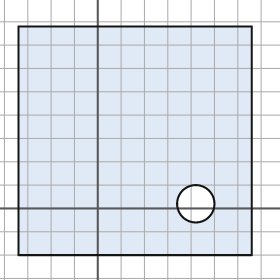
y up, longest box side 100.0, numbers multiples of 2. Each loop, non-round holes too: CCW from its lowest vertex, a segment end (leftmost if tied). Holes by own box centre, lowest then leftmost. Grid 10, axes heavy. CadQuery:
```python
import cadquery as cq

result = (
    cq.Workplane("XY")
    .moveTo(-34.0, -20.0)
    .lineTo(66.0, -20.0)
    .lineTo(66.0, 78.0)
    .lineTo(-34.0, 78.0)
    .close()
    .moveTo(42.0, 2.0)
    .circle(8.0)
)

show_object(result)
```